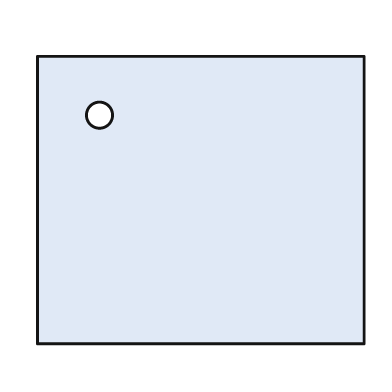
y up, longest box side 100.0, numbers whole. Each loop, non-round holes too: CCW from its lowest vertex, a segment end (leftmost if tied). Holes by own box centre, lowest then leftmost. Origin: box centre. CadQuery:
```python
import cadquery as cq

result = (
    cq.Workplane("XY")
    .moveTo(-50.0, -44.0)
    .lineTo(50.0, -44.0)
    .lineTo(50.0, 44.0)
    .lineTo(-50.0, 44.0)
    .close()
    .moveTo(-31.0, 26.0)
    .circle(4.0)
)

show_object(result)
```